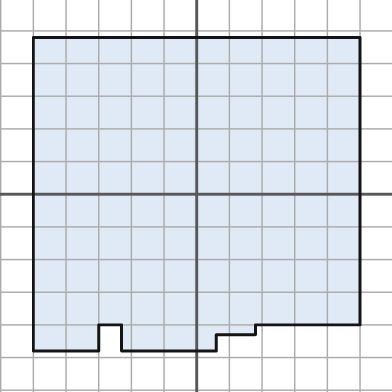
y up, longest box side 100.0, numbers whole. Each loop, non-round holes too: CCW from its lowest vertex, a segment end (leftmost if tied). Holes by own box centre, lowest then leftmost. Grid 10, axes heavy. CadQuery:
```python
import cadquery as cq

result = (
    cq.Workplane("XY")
    .moveTo(-50.0, -48.0)
    .lineTo(-30.0, -48.0)
    .lineTo(-30.0, -40.0)
    .lineTo(-23.0, -40.0)
    .lineTo(-23.0, -48.0)
    .lineTo(6.0, -48.0)
    .lineTo(6.0, -43.0)
    .lineTo(18.0, -43.0)
    .lineTo(18.0, -40.0)
    .lineTo(50.0, -40.0)
    .lineTo(50.0, 48.0)
    .lineTo(-50.0, 48.0)
    .close()
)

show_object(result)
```